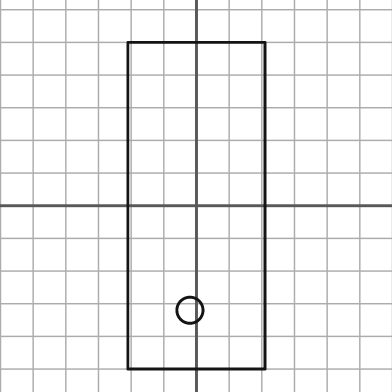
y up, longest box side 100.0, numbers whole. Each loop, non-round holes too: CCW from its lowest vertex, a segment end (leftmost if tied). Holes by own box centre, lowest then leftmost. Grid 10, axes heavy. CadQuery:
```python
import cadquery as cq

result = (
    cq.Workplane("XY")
    .moveTo(-21.0, -50.0)
    .lineTo(21.0, -50.0)
    .lineTo(21.0, 50.0)
    .lineTo(-21.0, 50.0)
    .close()
    .moveTo(-2.0, -32.0)
    .circle(4.0)
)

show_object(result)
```